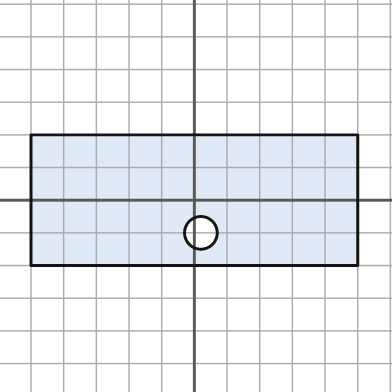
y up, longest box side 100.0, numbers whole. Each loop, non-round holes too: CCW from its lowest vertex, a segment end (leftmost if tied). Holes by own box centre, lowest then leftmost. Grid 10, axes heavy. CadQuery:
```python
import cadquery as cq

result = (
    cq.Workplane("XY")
    .moveTo(-50.0, -20.0)
    .lineTo(50.0, -20.0)
    .lineTo(50.0, 20.0)
    .lineTo(-50.0, 20.0)
    .close()
    .moveTo(2.0, -10.0)
    .circle(5.0)
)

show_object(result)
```